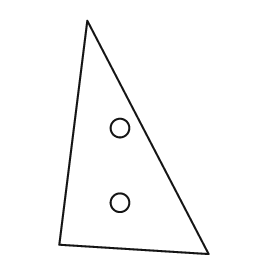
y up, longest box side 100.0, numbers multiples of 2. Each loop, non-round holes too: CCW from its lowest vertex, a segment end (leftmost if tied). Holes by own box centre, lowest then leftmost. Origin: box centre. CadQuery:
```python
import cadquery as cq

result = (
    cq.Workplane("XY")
    .moveTo(32.0, -50.0)
    .lineTo(-20.0, 50.0)
    .lineTo(-32.0, -46.0)
    .close()
    .moveTo(-6.0, -28.0)
    .circle(4.0)
    .moveTo(-6.0, 4.0)
    .circle(4.0)
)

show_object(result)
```